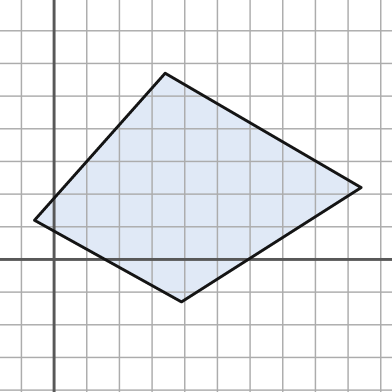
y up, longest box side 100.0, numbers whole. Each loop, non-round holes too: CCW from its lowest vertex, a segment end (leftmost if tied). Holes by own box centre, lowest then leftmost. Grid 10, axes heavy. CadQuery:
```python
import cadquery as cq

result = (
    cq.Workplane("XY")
    .moveTo(39.0, -13.0)
    .lineTo(94.0, 22.0)
    .lineTo(34.0, 57.0)
    .lineTo(-6.0, 12.0)
    .close()
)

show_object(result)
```